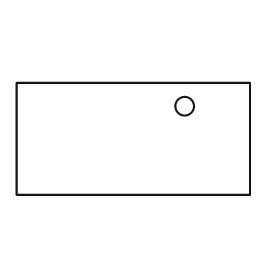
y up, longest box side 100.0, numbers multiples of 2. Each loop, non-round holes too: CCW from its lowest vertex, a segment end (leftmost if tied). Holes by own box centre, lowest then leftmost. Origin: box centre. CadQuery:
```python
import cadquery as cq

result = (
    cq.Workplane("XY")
    .moveTo(-50.0, -24.0)
    .lineTo(50.0, -24.0)
    .lineTo(50.0, 24.0)
    .lineTo(-50.0, 24.0)
    .close()
    .moveTo(22.0, 14.0)
    .circle(4.0)
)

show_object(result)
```